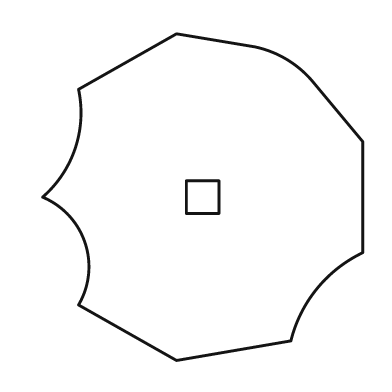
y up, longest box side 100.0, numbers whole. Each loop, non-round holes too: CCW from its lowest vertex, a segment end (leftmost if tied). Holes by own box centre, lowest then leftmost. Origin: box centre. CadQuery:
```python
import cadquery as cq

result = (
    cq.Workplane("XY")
    .moveTo(-8.0, -50.0)
    .lineTo(27.0, -44.0)
    .threePointArc((35.0, -28.0), (49.0, -17.0))
    .lineTo(49.0, 17.0)
    .lineTo(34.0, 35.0)
    .threePointArc((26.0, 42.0), (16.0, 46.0))
    .lineTo(-8.0, 50.0)
    .lineTo(-38.0, 33.0)
    .threePointArc((-39.0, 15.0), (-49.0, 0.0))
    .threePointArc((-36.0, -14.0), (-38.0, -33.0))
    .close()
    .moveTo(-5.0, -5.0)
    .lineTo(5.0, -5.0)
    .lineTo(5.0, 5.0)
    .lineTo(-5.0, 5.0)
    .close()
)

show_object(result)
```